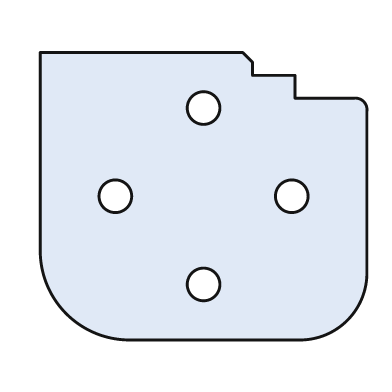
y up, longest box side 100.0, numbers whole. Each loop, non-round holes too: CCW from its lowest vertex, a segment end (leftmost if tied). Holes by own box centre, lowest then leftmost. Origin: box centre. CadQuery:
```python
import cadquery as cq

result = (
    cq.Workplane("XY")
    .moveTo(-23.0, -44.0)
    .lineTo(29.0, -44.0)
    .threePointArc((44.0, -38.0), (50.0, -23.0))
    .lineTo(50.0, 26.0)
    .threePointArc((49.0, 29.0), (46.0, 30.0))
    .lineTo(28.0, 30.0)
    .lineTo(28.0, 37.0)
    .lineTo(15.0, 37.0)
    .lineTo(15.0, 41.0)
    .lineTo(12.0, 44.0)
    .lineTo(-50.0, 44.0)
    .lineTo(-50.0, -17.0)
    .threePointArc((-42.0, -36.0), (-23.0, -44.0))
    .close()
    .moveTo(0.0, -27.0)
    .circle(5.0)
    .moveTo(-27.0, 0.0)
    .circle(5.0)
    .moveTo(27.0, 0.0)
    .circle(5.0)
    .moveTo(0.0, 27.0)
    .circle(5.0)
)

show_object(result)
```